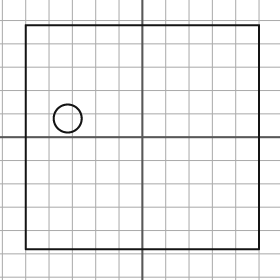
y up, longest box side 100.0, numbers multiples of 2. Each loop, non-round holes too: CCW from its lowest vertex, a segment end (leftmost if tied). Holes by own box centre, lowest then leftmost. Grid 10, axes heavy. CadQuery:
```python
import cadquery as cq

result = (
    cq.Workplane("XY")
    .moveTo(-50.0, -48.0)
    .lineTo(50.0, -48.0)
    .lineTo(50.0, 48.0)
    .lineTo(-50.0, 48.0)
    .close()
    .moveTo(-32.0, 8.0)
    .circle(6.0)
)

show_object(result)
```